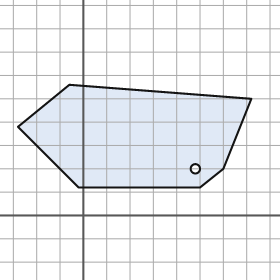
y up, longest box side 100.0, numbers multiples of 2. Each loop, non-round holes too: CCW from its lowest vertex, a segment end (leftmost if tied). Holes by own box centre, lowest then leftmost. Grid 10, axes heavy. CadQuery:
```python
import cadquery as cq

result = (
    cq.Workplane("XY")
    .moveTo(-2.0, 12.0)
    .lineTo(50.0, 12.0)
    .lineTo(60.0, 20.0)
    .lineTo(72.0, 50.0)
    .lineTo(-6.0, 56.0)
    .lineTo(-28.0, 38.0)
    .close()
    .moveTo(48.0, 20.0)
    .circle(2.0)
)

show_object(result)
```